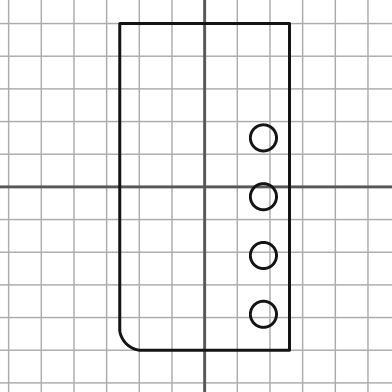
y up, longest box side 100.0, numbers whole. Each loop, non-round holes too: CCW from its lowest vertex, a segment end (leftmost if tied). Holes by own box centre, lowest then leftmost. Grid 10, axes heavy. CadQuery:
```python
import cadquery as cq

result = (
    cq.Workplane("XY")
    .moveTo(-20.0, -50.0)
    .lineTo(26.0, -50.0)
    .lineTo(26.0, 50.0)
    .lineTo(-26.0, 50.0)
    .lineTo(-26.0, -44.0)
    .threePointArc((-24.0, -48.0), (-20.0, -50.0))
    .close()
    .moveTo(18.0, -39.0)
    .circle(4.0)
    .moveTo(18.0, -21.0)
    .circle(4.0)
    .moveTo(18.0, -3.0)
    .circle(4.0)
    .moveTo(18.0, 15.0)
    .circle(4.0)
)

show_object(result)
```